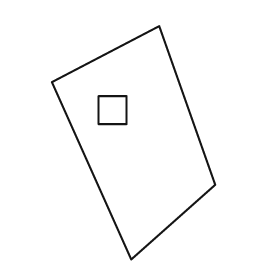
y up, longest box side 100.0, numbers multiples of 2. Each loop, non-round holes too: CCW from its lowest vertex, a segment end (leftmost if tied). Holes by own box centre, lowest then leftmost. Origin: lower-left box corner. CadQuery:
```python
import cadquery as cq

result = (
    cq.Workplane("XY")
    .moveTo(34.0, 0.0)
    .lineTo(70.0, 32.0)
    .lineTo(46.0, 100.0)
    .lineTo(0.0, 76.0)
    .close()
    .moveTo(20.0, 58.0)
    .lineTo(32.0, 58.0)
    .lineTo(32.0, 70.0)
    .lineTo(20.0, 70.0)
    .close()
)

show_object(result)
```